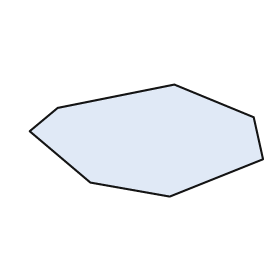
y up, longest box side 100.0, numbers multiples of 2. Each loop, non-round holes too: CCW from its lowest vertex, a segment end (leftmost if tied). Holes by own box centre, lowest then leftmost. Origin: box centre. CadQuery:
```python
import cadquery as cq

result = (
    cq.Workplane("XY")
    .moveTo(10.0, -24.0)
    .lineTo(50.0, -8.0)
    .lineTo(46.0, 10.0)
    .lineTo(12.0, 24.0)
    .lineTo(-38.0, 14.0)
    .lineTo(-50.0, 4.0)
    .lineTo(-24.0, -18.0)
    .close()
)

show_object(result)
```